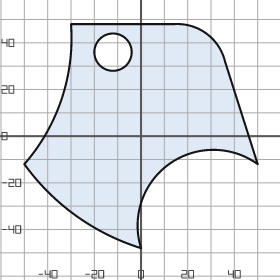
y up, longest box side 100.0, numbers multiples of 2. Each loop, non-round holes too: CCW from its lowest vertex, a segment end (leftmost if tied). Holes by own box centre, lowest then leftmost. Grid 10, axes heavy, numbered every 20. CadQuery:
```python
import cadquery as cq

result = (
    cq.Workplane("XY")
    .moveTo(0.0, -48.0)
    .threePointArc((12.0, -12.0), (50.0, -12.0))
    .lineTo(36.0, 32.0)
    .threePointArc((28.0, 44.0), (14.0, 48.0))
    .lineTo(-30.0, 48.0)
    .threePointArc((-34.0, 16.0), (-50.0, -12.0))
    .threePointArc((-28.0, -34.0), (0.0, -48.0))
    .close()
    .moveTo(-12.0, 36.0)
    .circle(8.0)
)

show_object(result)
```